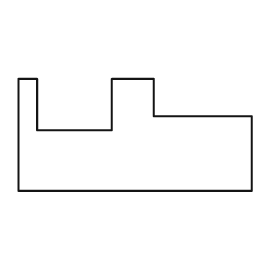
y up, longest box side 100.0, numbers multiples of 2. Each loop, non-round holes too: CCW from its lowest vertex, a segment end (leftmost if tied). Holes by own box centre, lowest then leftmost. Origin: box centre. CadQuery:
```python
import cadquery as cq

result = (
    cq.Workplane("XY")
    .moveTo(-50.0, -24.0)
    .lineTo(50.0, -24.0)
    .lineTo(50.0, 8.0)
    .lineTo(8.0, 8.0)
    .lineTo(8.0, 24.0)
    .lineTo(-10.0, 24.0)
    .lineTo(-10.0, 2.0)
    .lineTo(-42.0, 2.0)
    .lineTo(-42.0, 24.0)
    .lineTo(-50.0, 24.0)
    .close()
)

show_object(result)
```